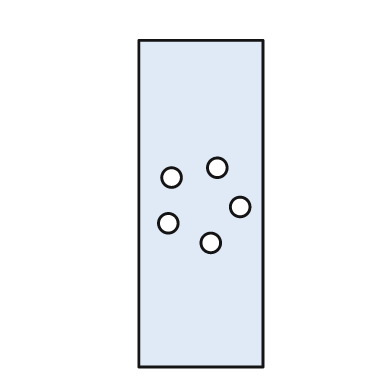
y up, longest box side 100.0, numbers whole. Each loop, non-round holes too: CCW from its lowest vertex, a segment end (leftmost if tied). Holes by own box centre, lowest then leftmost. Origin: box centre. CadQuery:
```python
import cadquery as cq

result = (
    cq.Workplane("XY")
    .moveTo(-19.0, -50.0)
    .lineTo(19.0, -50.0)
    .lineTo(19.0, 50.0)
    .lineTo(-19.0, 50.0)
    .close()
    .moveTo(3.0, -12.0)
    .circle(3.0)
    .moveTo(-10.0, -6.0)
    .circle(3.0)
    .moveTo(12.0, -1.0)
    .circle(3.0)
    .moveTo(-9.0, 8.0)
    .circle(3.0)
    .moveTo(5.0, 11.0)
    .circle(3.0)
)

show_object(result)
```